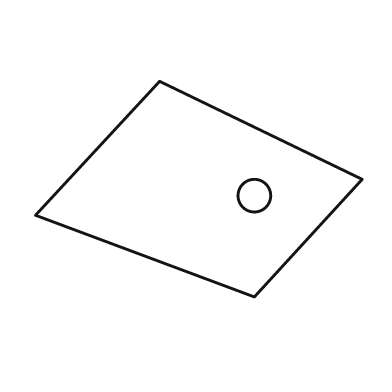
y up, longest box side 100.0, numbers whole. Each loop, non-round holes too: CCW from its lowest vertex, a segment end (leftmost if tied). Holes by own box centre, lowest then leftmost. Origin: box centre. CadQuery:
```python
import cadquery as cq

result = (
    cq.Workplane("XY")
    .moveTo(17.0, -33.0)
    .lineTo(50.0, 3.0)
    .lineTo(-12.0, 33.0)
    .lineTo(-50.0, -8.0)
    .close()
    .moveTo(17.0, -2.0)
    .circle(5.0)
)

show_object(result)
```